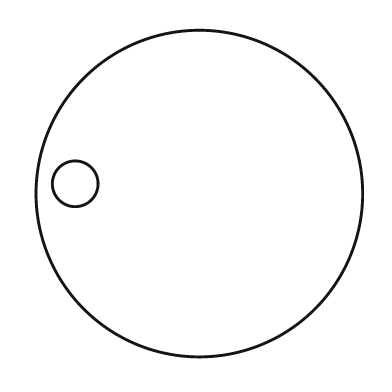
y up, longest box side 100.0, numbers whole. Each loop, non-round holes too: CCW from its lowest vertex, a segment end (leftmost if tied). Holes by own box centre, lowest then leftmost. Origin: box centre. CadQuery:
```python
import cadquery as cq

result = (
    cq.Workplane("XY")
    .moveTo(0.0, 0.0)
    .circle(50.0)
    .moveTo(-38.0, 3.0)
    .circle(7.0)
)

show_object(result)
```